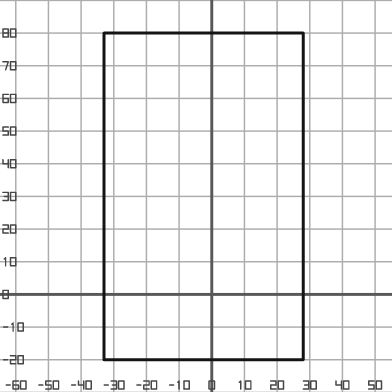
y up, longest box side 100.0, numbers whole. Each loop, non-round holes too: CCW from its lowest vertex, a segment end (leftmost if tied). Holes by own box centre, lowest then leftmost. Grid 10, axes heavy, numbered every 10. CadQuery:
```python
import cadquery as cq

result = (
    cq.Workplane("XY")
    .moveTo(-33.0, -20.0)
    .lineTo(28.0, -20.0)
    .lineTo(28.0, 80.0)
    .lineTo(-33.0, 80.0)
    .close()
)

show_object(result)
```